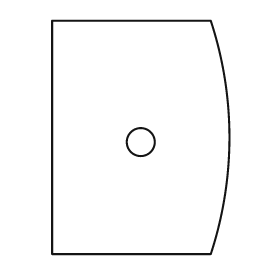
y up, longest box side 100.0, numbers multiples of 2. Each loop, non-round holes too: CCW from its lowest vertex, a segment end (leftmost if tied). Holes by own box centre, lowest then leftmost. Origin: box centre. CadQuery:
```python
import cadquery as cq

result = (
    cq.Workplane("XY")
    .moveTo(-38.0, -50.0)
    .lineTo(30.0, -50.0)
    .threePointArc((38.0, 0.0), (30.0, 50.0))
    .lineTo(-38.0, 50.0)
    .close()
    .moveTo(0.0, -2.0)
    .circle(6.0)
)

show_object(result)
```